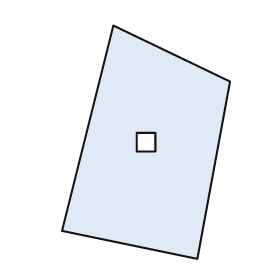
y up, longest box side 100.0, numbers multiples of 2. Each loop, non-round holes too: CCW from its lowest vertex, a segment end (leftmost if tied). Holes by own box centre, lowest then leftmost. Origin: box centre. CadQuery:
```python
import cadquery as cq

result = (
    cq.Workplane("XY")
    .moveTo(22.0, -50.0)
    .lineTo(36.0, 26.0)
    .lineTo(-14.0, 50.0)
    .lineTo(-36.0, -38.0)
    .close()
    .moveTo(-4.0, -4.0)
    .lineTo(4.0, -4.0)
    .lineTo(4.0, 4.0)
    .lineTo(-4.0, 4.0)
    .close()
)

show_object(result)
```